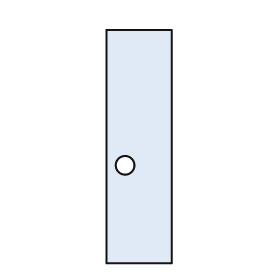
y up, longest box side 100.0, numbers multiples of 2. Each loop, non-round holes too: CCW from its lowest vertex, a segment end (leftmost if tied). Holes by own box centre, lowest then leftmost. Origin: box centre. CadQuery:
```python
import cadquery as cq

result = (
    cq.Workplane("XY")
    .moveTo(-14.0, -50.0)
    .lineTo(14.0, -50.0)
    .lineTo(14.0, 50.0)
    .lineTo(-14.0, 50.0)
    .close()
    .moveTo(-6.0, -8.0)
    .circle(4.0)
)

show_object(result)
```